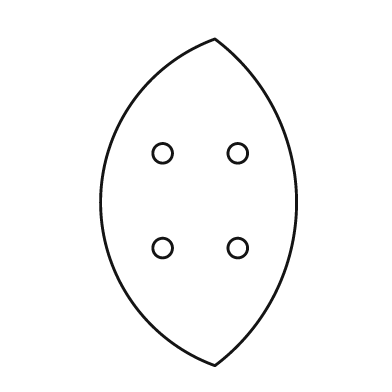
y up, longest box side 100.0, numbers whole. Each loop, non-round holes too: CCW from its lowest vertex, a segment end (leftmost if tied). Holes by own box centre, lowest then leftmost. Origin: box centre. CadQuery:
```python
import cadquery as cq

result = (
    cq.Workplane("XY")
    .moveTo(5.0, -50.0)
    .threePointArc((30.0, 0.0), (5.0, 50.0))
    .threePointArc((-30.0, 0.0), (5.0, -50.0))
    .close()
    .moveTo(-11.0, -14.0)
    .circle(3.0)
    .moveTo(12.0, -14.0)
    .circle(3.0)
    .moveTo(-11.0, 15.0)
    .circle(3.0)
    .moveTo(12.0, 15.0)
    .circle(3.0)
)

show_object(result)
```